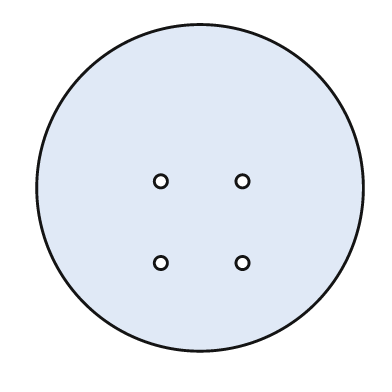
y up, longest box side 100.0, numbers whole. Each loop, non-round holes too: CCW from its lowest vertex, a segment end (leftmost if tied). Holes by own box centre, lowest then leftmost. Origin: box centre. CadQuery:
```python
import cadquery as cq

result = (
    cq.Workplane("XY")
    .moveTo(0.0, 0.0)
    .circle(50.0)
    .moveTo(-12.0, -23.0)
    .circle(2.0)
    .moveTo(13.0, -23.0)
    .circle(2.0)
    .moveTo(-12.0, 2.0)
    .circle(2.0)
    .moveTo(13.0, 2.0)
    .circle(2.0)
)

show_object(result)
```